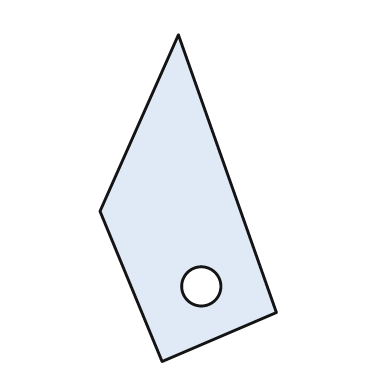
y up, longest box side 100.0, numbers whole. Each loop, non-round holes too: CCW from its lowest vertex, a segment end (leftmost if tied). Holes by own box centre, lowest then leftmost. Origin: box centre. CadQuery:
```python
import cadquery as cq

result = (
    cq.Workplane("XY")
    .moveTo(-8.0, -50.0)
    .lineTo(27.0, -35.0)
    .lineTo(-3.0, 50.0)
    .lineTo(-27.0, -4.0)
    .close()
    .moveTo(4.0, -27.0)
    .circle(6.0)
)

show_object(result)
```